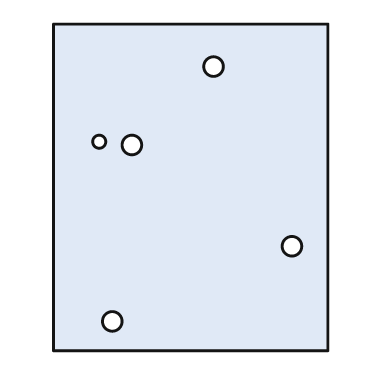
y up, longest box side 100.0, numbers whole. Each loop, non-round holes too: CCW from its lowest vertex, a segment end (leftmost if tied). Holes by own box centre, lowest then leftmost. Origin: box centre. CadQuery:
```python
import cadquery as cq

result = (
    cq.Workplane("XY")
    .moveTo(-42.0, -50.0)
    .lineTo(42.0, -50.0)
    .lineTo(42.0, 50.0)
    .lineTo(-42.0, 50.0)
    .close()
    .moveTo(-24.0, -41.0)
    .circle(3.0)
    .moveTo(31.0, -18.0)
    .circle(3.0)
    .moveTo(-18.0, 13.0)
    .circle(3.0)
    .moveTo(-28.0, 14.0)
    .circle(2.0)
    .moveTo(7.0, 37.0)
    .circle(3.0)
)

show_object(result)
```